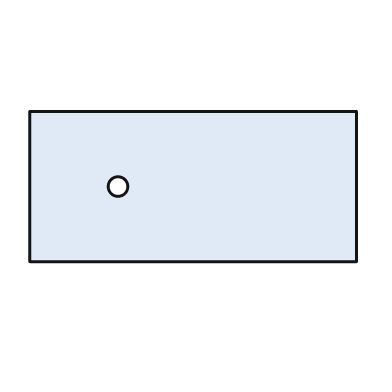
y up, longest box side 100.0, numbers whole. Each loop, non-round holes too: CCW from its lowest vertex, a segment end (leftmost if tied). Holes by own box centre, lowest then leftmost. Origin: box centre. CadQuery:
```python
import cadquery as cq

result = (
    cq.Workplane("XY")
    .moveTo(-50.0, -23.0)
    .lineTo(50.0, -23.0)
    .lineTo(50.0, 23.0)
    .lineTo(-50.0, 23.0)
    .close()
    .moveTo(-23.0, 0.0)
    .circle(3.0)
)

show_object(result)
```